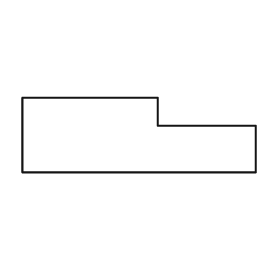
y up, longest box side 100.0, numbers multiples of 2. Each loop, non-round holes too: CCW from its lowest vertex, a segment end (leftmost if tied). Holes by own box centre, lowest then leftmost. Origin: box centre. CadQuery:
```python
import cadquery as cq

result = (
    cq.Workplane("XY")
    .moveTo(-50.0, -16.0)
    .lineTo(50.0, -16.0)
    .lineTo(50.0, 4.0)
    .lineTo(8.0, 4.0)
    .lineTo(8.0, 16.0)
    .lineTo(-50.0, 16.0)
    .close()
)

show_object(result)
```